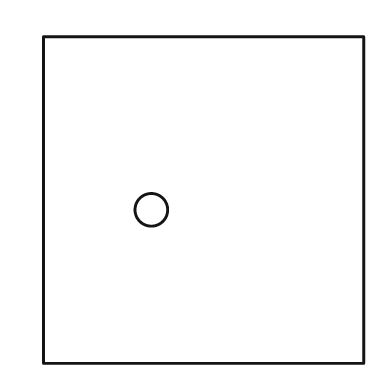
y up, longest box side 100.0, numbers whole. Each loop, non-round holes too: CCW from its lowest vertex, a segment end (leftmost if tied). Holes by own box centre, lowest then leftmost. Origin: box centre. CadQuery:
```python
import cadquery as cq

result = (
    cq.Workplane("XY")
    .moveTo(-49.0, -50.0)
    .lineTo(49.0, -50.0)
    .lineTo(49.0, 50.0)
    .lineTo(-49.0, 50.0)
    .close()
    .moveTo(-16.0, -3.0)
    .circle(5.0)
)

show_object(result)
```